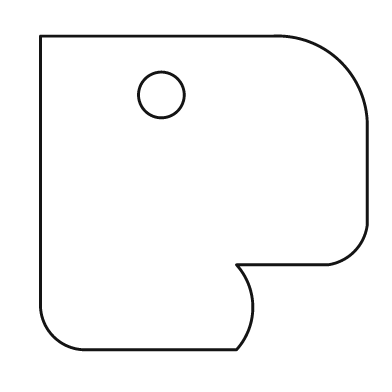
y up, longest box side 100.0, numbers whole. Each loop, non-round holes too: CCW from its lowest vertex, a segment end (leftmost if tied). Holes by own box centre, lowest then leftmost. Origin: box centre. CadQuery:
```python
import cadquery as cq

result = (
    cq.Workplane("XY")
    .moveTo(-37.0, -48.0)
    .lineTo(10.0, -48.0)
    .threePointArc((15.0, -35.0), (10.0, -22.0))
    .lineTo(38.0, -22.0)
    .threePointArc((46.0, -18.0), (50.0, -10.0))
    .lineTo(50.0, 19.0)
    .threePointArc((42.0, 40.0), (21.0, 48.0))
    .lineTo(-50.0, 48.0)
    .lineTo(-50.0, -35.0)
    .threePointArc((-46.0, -44.0), (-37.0, -48.0))
    .close()
    .moveTo(-13.0, 30.0)
    .circle(7.0)
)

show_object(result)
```